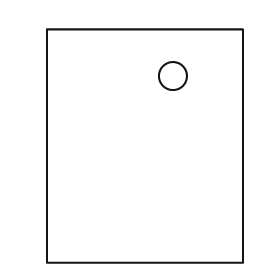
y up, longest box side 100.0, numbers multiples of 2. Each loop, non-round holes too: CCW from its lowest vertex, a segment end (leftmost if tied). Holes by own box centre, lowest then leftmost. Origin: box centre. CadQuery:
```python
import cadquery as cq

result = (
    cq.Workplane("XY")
    .moveTo(-42.0, -50.0)
    .lineTo(42.0, -50.0)
    .lineTo(42.0, 50.0)
    .lineTo(-42.0, 50.0)
    .close()
    .moveTo(12.0, 30.0)
    .circle(6.0)
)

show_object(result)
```